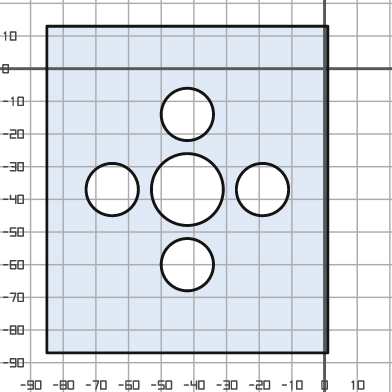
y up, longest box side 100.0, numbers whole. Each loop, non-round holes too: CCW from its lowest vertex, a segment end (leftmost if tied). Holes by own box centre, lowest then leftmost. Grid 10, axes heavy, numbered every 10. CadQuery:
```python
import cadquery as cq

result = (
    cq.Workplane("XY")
    .moveTo(-85.0, -87.0)
    .lineTo(1.0, -87.0)
    .lineTo(1.0, 13.0)
    .lineTo(-85.0, 13.0)
    .close()
    .moveTo(-42.0, -60.0)
    .circle(8.0)
    .moveTo(-65.0, -37.0)
    .circle(8.0)
    .moveTo(-42.0, -37.0)
    .circle(11.0)
    .moveTo(-19.0, -37.0)
    .circle(8.0)
    .moveTo(-42.0, -14.0)
    .circle(8.0)
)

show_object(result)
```